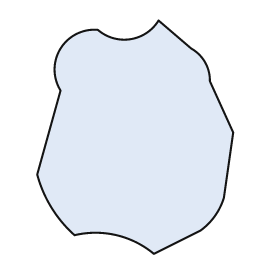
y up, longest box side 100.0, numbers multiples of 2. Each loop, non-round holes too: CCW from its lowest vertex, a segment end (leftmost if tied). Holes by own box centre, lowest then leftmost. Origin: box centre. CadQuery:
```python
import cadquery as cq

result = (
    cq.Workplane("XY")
    .moveTo(8.0, -50.0)
    .lineTo(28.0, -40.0)
    .threePointArc((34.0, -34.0), (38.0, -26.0))
    .lineTo(42.0, 2.0)
    .lineTo(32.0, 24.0)
    .threePointArc((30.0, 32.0), (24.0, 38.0))
    .lineTo(10.0, 50.0)
    .threePointArc((-2.0, 42.0), (-16.0, 46.0))
    .threePointArc((-32.0, 38.0), (-32.0, 20.0))
    .lineTo(-42.0, -16.0)
    .threePointArc((-36.0, -30.0), (-26.0, -42.0))
    .threePointArc((-8.0, -42.0), (8.0, -50.0))
    .close()
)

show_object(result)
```